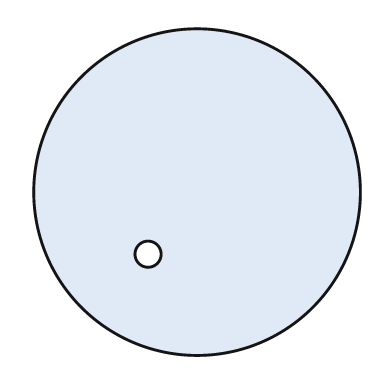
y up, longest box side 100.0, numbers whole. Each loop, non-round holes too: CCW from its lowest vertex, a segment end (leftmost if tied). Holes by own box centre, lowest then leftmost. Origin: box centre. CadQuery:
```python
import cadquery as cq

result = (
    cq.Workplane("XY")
    .moveTo(0.0, 0.0)
    .circle(50.0)
    .moveTo(-15.0, -19.0)
    .circle(4.0)
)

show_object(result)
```